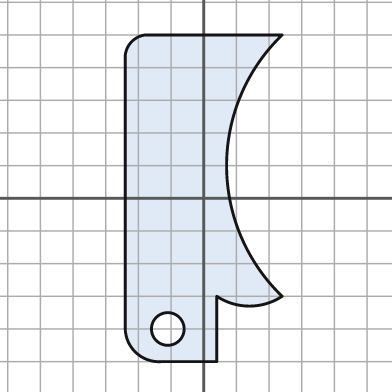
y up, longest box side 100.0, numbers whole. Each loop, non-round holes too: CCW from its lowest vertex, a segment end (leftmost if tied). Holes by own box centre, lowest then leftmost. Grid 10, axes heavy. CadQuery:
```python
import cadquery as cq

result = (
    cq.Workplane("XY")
    .moveTo(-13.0, -50.0)
    .lineTo(4.0, -50.0)
    .lineTo(4.0, -30.0)
    .threePointArc((14.0, -33.0), (24.0, -30.0))
    .threePointArc((7.0, 10.0), (24.0, 50.0))
    .lineTo(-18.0, 50.0)
    .threePointArc((-22.0, 48.0), (-24.0, 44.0))
    .lineTo(-24.0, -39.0)
    .threePointArc((-21.0, -47.0), (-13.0, -50.0))
    .close()
    .moveTo(-11.0, -40.0)
    .circle(5.0)
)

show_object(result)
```